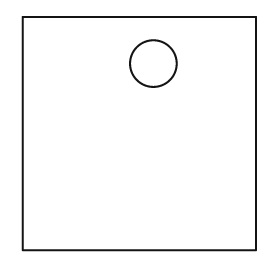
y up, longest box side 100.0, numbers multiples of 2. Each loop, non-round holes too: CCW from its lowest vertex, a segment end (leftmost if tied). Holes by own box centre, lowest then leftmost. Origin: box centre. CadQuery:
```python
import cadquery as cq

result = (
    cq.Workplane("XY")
    .moveTo(-50.0, -50.0)
    .lineTo(50.0, -50.0)
    .lineTo(50.0, 50.0)
    .lineTo(-50.0, 50.0)
    .close()
    .moveTo(6.0, 30.0)
    .circle(10.0)
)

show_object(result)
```